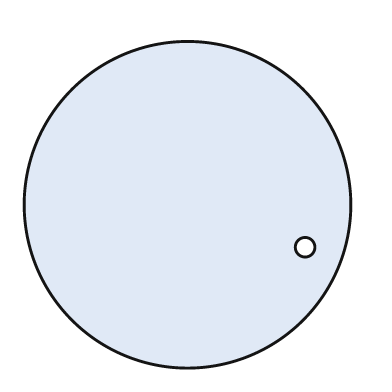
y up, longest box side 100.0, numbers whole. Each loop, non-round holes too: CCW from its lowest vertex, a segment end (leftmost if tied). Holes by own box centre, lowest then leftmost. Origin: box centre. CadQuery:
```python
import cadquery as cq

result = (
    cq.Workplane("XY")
    .moveTo(0.0, 0.0)
    .circle(50.0)
    .moveTo(36.0, -13.0)
    .circle(3.0)
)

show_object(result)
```